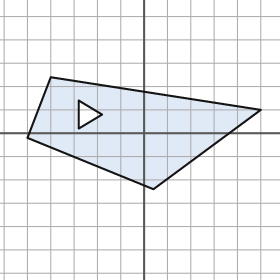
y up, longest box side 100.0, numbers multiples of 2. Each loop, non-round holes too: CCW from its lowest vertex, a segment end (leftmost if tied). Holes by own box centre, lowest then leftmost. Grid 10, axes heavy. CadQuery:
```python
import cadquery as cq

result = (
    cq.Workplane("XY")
    .moveTo(4.0, -24.0)
    .lineTo(50.0, 10.0)
    .lineTo(-40.0, 24.0)
    .lineTo(-50.0, -2.0)
    .close()
    .moveTo(-28.0, 2.0)
    .lineTo(-18.0, 8.0)
    .lineTo(-28.0, 14.0)
    .close()
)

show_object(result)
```